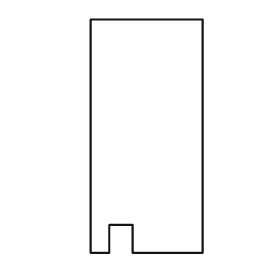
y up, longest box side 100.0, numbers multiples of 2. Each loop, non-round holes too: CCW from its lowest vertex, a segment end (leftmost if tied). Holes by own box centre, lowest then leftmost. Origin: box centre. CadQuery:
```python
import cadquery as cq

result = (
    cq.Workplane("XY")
    .moveTo(-24.0, -50.0)
    .lineTo(-16.0, -50.0)
    .lineTo(-16.0, -38.0)
    .lineTo(-6.0, -38.0)
    .lineTo(-6.0, -50.0)
    .lineTo(24.0, -50.0)
    .lineTo(24.0, 50.0)
    .lineTo(-24.0, 50.0)
    .close()
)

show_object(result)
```